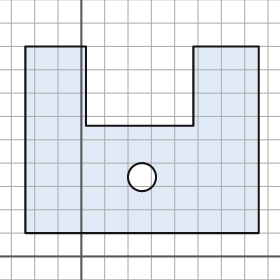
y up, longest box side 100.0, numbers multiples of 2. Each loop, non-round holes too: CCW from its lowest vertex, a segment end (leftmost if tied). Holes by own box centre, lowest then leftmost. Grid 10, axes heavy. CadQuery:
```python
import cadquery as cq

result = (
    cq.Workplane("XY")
    .moveTo(-24.0, 10.0)
    .lineTo(76.0, 10.0)
    .lineTo(76.0, 90.0)
    .lineTo(48.0, 90.0)
    .lineTo(48.0, 56.0)
    .lineTo(2.0, 56.0)
    .lineTo(2.0, 90.0)
    .lineTo(-24.0, 90.0)
    .close()
    .moveTo(26.0, 34.0)
    .circle(6.0)
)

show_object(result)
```